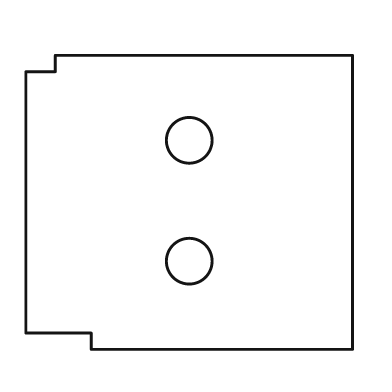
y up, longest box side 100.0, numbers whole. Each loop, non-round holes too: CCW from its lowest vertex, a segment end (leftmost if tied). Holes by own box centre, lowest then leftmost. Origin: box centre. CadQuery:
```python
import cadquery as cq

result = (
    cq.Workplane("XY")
    .moveTo(-30.0, -45.0)
    .lineTo(50.0, -45.0)
    .lineTo(50.0, 45.0)
    .lineTo(-41.0, 45.0)
    .lineTo(-41.0, 40.0)
    .lineTo(-50.0, 40.0)
    .lineTo(-50.0, -40.0)
    .lineTo(-30.0, -40.0)
    .close()
    .moveTo(0.0, -18.0)
    .circle(7.0)
    .moveTo(0.0, 19.0)
    .circle(7.0)
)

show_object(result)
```